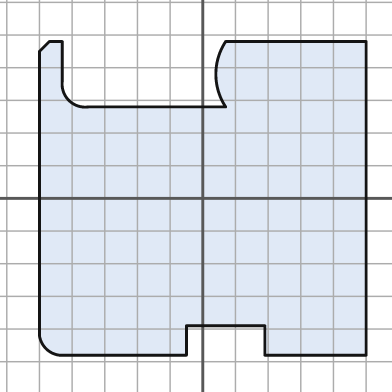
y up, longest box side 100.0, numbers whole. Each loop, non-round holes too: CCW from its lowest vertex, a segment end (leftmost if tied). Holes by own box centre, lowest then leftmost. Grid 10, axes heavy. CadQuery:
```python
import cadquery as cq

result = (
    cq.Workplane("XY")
    .moveTo(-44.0, -48.0)
    .lineTo(-5.0, -48.0)
    .lineTo(-5.0, -39.0)
    .lineTo(19.0, -39.0)
    .lineTo(19.0, -48.0)
    .lineTo(50.0, -48.0)
    .lineTo(50.0, 48.0)
    .lineTo(7.0, 48.0)
    .threePointArc((4.0, 38.0), (7.0, 28.0))
    .lineTo(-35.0, 28.0)
    .threePointArc((-41.0, 30.0), (-43.0, 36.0))
    .lineTo(-43.0, 48.0)
    .lineTo(-47.0, 48.0)
    .lineTo(-50.0, 45.0)
    .lineTo(-50.0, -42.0)
    .threePointArc((-48.0, -46.0), (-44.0, -48.0))
    .close()
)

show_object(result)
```